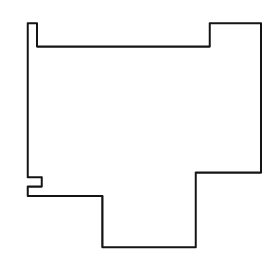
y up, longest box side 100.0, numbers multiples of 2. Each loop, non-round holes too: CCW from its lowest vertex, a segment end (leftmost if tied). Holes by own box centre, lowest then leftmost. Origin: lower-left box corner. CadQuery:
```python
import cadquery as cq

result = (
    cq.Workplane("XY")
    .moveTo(32.0, 0.0)
    .lineTo(72.0, 0.0)
    .lineTo(72.0, 32.0)
    .lineTo(100.0, 32.0)
    .lineTo(100.0, 96.0)
    .lineTo(78.0, 96.0)
    .lineTo(78.0, 86.0)
    .lineTo(4.0, 86.0)
    .lineTo(4.0, 96.0)
    .lineTo(0.0, 96.0)
    .lineTo(0.0, 30.0)
    .lineTo(6.0, 30.0)
    .lineTo(6.0, 26.0)
    .lineTo(0.0, 26.0)
    .lineTo(0.0, 22.0)
    .lineTo(32.0, 22.0)
    .close()
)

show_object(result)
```